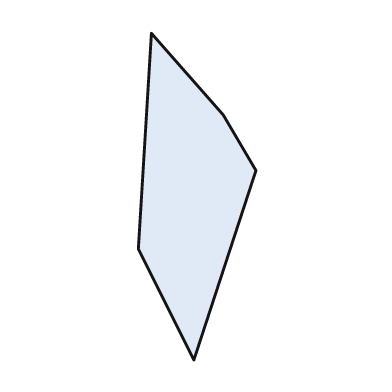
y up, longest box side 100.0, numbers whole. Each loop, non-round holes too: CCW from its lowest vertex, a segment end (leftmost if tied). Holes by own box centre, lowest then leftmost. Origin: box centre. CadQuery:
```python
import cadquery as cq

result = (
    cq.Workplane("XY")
    .moveTo(-1.0, -50.0)
    .lineTo(18.0, 8.0)
    .lineTo(8.0, 25.0)
    .lineTo(-14.0, 50.0)
    .lineTo(-18.0, -16.0)
    .close()
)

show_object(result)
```